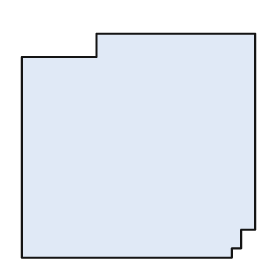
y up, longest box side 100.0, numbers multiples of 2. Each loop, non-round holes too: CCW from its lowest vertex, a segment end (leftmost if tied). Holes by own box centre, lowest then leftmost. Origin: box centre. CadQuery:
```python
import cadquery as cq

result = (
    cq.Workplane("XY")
    .moveTo(-50.0, -48.0)
    .lineTo(40.0, -48.0)
    .lineTo(40.0, -44.0)
    .lineTo(44.0, -44.0)
    .lineTo(44.0, -36.0)
    .lineTo(50.0, -36.0)
    .lineTo(50.0, 48.0)
    .lineTo(-18.0, 48.0)
    .lineTo(-18.0, 38.0)
    .lineTo(-50.0, 38.0)
    .close()
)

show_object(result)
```